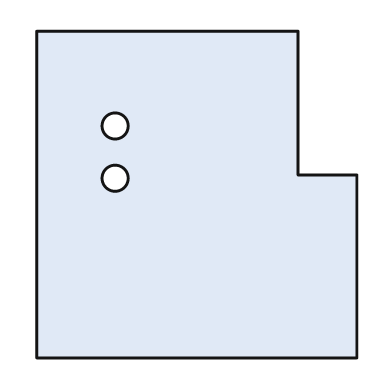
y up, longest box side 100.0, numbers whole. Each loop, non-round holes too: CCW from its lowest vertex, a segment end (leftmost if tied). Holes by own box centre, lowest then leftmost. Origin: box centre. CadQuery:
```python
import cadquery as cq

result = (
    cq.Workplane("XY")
    .moveTo(-49.0, -50.0)
    .lineTo(49.0, -50.0)
    .lineTo(49.0, 6.0)
    .lineTo(31.0, 6.0)
    .lineTo(31.0, 50.0)
    .lineTo(-49.0, 50.0)
    .close()
    .moveTo(-25.0, 5.0)
    .circle(4.0)
    .moveTo(-25.0, 21.0)
    .circle(4.0)
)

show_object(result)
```